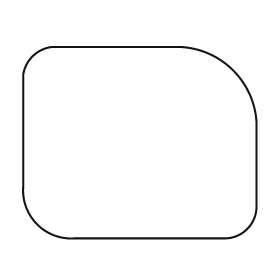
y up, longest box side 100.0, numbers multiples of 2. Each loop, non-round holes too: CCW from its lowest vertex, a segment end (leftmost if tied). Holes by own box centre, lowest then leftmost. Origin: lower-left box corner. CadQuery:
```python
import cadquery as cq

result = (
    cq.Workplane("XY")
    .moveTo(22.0, 0.0)
    .lineTo(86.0, 0.0)
    .threePointArc((96.0, 4.0), (100.0, 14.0))
    .lineTo(100.0, 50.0)
    .threePointArc((90.0, 72.0), (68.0, 82.0))
    .lineTo(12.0, 82.0)
    .threePointArc((4.0, 78.0), (0.0, 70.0))
    .lineTo(0.0, 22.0)
    .threePointArc((6.0, 6.0), (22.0, 0.0))
    .close()
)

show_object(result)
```